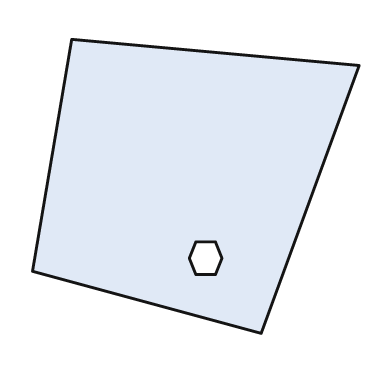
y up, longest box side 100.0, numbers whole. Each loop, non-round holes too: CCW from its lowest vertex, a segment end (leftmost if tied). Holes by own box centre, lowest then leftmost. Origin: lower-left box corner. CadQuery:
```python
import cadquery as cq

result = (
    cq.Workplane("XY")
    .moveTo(70.0, 0.0)
    .lineTo(100.0, 82.0)
    .lineTo(12.0, 90.0)
    .lineTo(0.0, 19.0)
    .close()
    .moveTo(50.0, 18.0)
    .lineTo(56.0, 18.0)
    .lineTo(58.0, 23.0)
    .lineTo(56.0, 28.0)
    .lineTo(50.0, 28.0)
    .lineTo(48.0, 23.0)
    .close()
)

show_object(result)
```